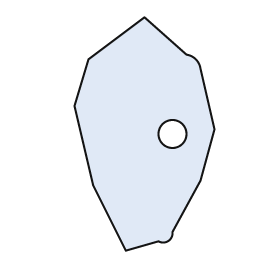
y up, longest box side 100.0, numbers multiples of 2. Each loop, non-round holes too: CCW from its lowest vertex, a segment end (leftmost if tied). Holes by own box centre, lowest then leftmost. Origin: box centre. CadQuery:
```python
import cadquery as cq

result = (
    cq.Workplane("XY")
    .moveTo(-8.0, -50.0)
    .lineTo(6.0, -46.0)
    .threePointArc((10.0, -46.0), (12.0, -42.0))
    .lineTo(24.0, -20.0)
    .lineTo(30.0, 2.0)
    .lineTo(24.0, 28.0)
    .threePointArc((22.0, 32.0), (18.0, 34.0))
    .lineTo(0.0, 50.0)
    .lineTo(-24.0, 32.0)
    .lineTo(-30.0, 12.0)
    .lineTo(-22.0, -22.0)
    .close()
    .moveTo(12.0, 0.0)
    .circle(6.0)
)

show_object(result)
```